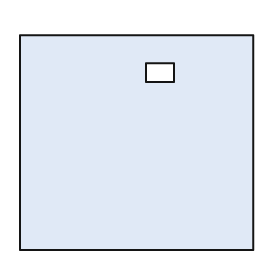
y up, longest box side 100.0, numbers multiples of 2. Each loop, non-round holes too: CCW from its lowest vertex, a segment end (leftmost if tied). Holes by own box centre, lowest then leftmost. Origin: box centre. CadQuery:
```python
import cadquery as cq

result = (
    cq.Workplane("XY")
    .moveTo(-50.0, -46.0)
    .lineTo(50.0, -46.0)
    .lineTo(50.0, 46.0)
    .lineTo(-50.0, 46.0)
    .close()
    .moveTo(4.0, 26.0)
    .lineTo(16.0, 26.0)
    .lineTo(16.0, 34.0)
    .lineTo(4.0, 34.0)
    .close()
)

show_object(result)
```